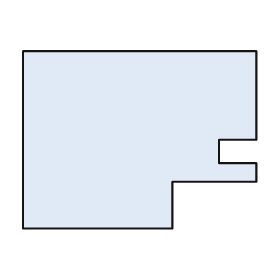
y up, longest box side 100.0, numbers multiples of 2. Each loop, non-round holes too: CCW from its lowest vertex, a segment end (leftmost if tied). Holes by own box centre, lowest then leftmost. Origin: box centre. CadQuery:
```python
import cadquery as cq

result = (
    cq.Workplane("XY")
    .moveTo(-50.0, -38.0)
    .lineTo(14.0, -38.0)
    .lineTo(14.0, -18.0)
    .lineTo(50.0, -18.0)
    .lineTo(50.0, -10.0)
    .lineTo(34.0, -10.0)
    .lineTo(34.0, 0.0)
    .lineTo(50.0, 0.0)
    .lineTo(50.0, 38.0)
    .lineTo(-50.0, 38.0)
    .close()
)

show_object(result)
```